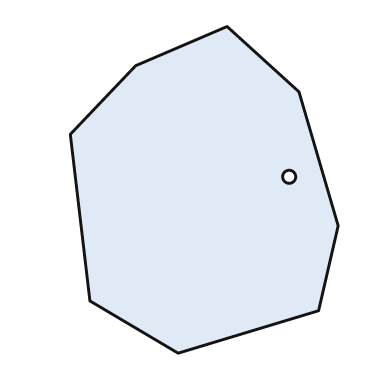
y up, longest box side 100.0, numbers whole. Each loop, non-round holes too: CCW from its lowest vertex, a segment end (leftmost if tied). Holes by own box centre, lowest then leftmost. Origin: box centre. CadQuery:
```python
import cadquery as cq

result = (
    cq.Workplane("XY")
    .moveTo(-8.0, -50.0)
    .lineTo(35.0, -37.0)
    .lineTo(41.0, -11.0)
    .lineTo(29.0, 30.0)
    .lineTo(7.0, 50.0)
    .lineTo(-21.0, 38.0)
    .lineTo(-41.0, 17.0)
    .lineTo(-35.0, -34.0)
    .close()
    .moveTo(26.0, 4.0)
    .circle(2.0)
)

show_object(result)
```